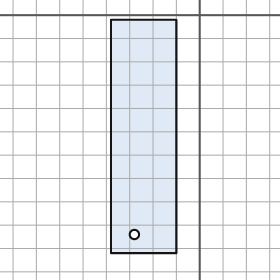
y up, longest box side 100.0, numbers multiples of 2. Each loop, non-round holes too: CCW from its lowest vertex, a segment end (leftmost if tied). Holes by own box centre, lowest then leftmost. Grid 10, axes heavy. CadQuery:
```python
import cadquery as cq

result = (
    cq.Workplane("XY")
    .moveTo(-38.0, -102.0)
    .lineTo(-10.0, -102.0)
    .lineTo(-10.0, -2.0)
    .lineTo(-38.0, -2.0)
    .close()
    .moveTo(-28.0, -94.0)
    .circle(2.0)
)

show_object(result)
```